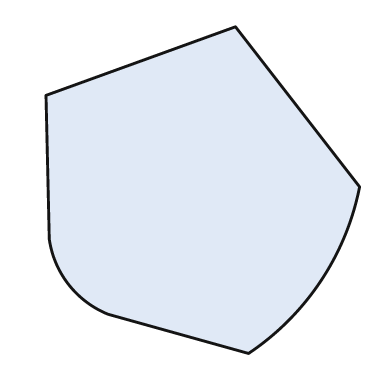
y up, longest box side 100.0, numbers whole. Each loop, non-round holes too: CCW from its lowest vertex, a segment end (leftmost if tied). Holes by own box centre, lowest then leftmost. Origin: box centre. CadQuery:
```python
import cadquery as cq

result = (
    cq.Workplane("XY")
    .moveTo(14.0, -50.0)
    .threePointArc((36.0, -28.0), (48.0, 1.0))
    .lineTo(10.0, 50.0)
    .lineTo(-48.0, 29.0)
    .lineTo(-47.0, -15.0)
    .threePointArc((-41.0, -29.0), (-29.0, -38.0))
    .close()
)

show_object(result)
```